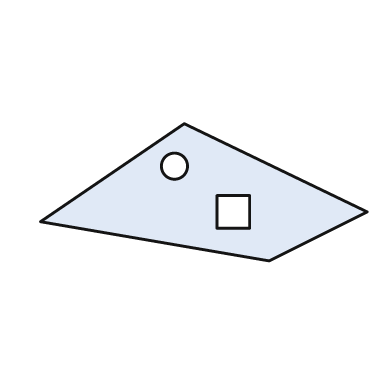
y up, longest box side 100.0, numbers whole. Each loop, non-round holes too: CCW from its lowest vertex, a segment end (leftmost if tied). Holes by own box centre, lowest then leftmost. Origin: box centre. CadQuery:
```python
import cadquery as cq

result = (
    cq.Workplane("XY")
    .moveTo(20.0, -21.0)
    .lineTo(50.0, -6.0)
    .lineTo(-6.0, 21.0)
    .lineTo(-50.0, -9.0)
    .close()
    .moveTo(4.0, -11.0)
    .lineTo(14.0, -11.0)
    .lineTo(14.0, -1.0)
    .lineTo(4.0, -1.0)
    .close()
    .moveTo(-9.0, 8.0)
    .circle(4.0)
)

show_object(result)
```